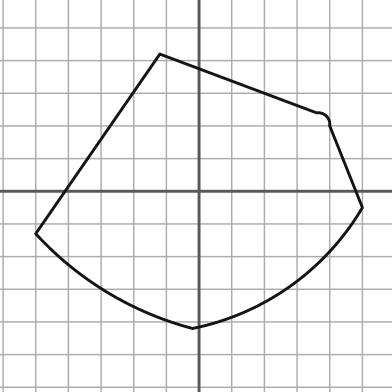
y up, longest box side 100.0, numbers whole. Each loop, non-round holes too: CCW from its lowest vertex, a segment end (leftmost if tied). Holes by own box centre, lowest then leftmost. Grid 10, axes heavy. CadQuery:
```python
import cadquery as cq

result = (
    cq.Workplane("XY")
    .moveTo(-2.0, -42.0)
    .threePointArc((28.0, -29.0), (50.0, -5.0))
    .lineTo(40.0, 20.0)
    .threePointArc((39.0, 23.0), (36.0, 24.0))
    .lineTo(-12.0, 42.0)
    .lineTo(-50.0, -13.0)
    .threePointArc((-28.0, -31.0), (-2.0, -42.0))
    .close()
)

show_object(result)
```